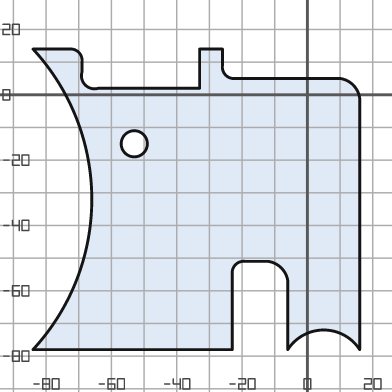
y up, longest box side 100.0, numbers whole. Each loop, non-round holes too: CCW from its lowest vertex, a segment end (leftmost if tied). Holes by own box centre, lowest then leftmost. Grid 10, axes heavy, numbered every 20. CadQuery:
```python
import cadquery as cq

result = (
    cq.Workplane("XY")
    .moveTo(-84.0, -78.0)
    .lineTo(-23.0, -78.0)
    .lineTo(-23.0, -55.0)
    .threePointArc((-22.0, -52.0), (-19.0, -51.0))
    .lineTo(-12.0, -51.0)
    .threePointArc((-8.0, -53.0), (-6.0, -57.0))
    .lineTo(-6.0, -78.0)
    .threePointArc((5.0, -72.0), (16.0, -78.0))
    .lineTo(16.0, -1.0)
    .threePointArc((14.0, 3.0), (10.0, 5.0))
    .lineTo(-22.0, 5.0)
    .threePointArc((-25.0, 6.0), (-26.0, 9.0))
    .lineTo(-26.0, 14.0)
    .lineTo(-33.0, 14.0)
    .lineTo(-33.0, 2.0)
    .lineTo(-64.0, 2.0)
    .threePointArc((-68.0, 3.0), (-69.0, 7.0))
    .lineTo(-69.0, 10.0)
    .threePointArc((-70.0, 13.0), (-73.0, 14.0))
    .lineTo(-84.0, 14.0)
    .threePointArc((-66.0, -32.0), (-84.0, -78.0))
    .close()
    .moveTo(-53.0, -15.0)
    .circle(4.0)
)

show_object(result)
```